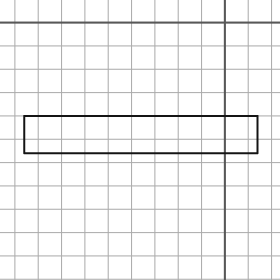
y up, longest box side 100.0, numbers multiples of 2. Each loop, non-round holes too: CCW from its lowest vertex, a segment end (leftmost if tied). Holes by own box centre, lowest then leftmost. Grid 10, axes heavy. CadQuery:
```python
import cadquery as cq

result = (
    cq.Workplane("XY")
    .moveTo(-86.0, -56.0)
    .lineTo(14.0, -56.0)
    .lineTo(14.0, -40.0)
    .lineTo(-86.0, -40.0)
    .close()
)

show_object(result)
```